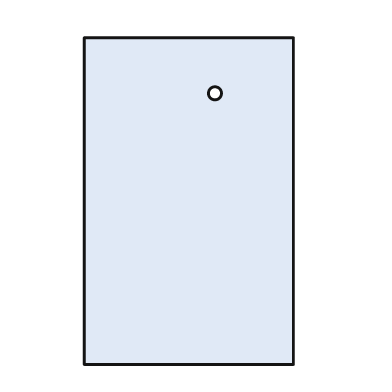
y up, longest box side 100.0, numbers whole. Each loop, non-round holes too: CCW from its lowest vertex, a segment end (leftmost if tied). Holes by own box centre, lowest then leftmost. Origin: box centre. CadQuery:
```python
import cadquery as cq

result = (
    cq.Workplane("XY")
    .moveTo(-32.0, -50.0)
    .lineTo(32.0, -50.0)
    .lineTo(32.0, 50.0)
    .lineTo(-32.0, 50.0)
    .close()
    .moveTo(8.0, 33.0)
    .circle(2.0)
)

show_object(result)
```